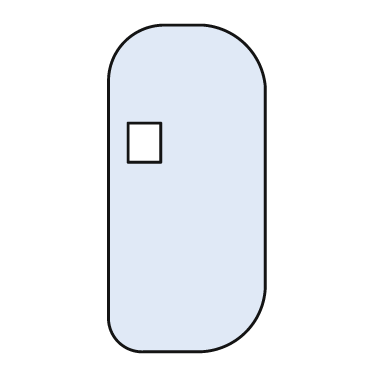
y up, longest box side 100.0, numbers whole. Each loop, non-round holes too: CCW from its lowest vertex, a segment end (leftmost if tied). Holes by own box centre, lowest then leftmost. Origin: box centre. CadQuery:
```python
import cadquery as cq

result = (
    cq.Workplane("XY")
    .moveTo(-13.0, -50.0)
    .lineTo(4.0, -50.0)
    .threePointArc((18.0, -44.0), (24.0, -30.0))
    .lineTo(24.0, 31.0)
    .threePointArc((18.0, 44.0), (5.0, 50.0))
    .lineTo(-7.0, 50.0)
    .threePointArc((-19.0, 45.0), (-24.0, 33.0))
    .lineTo(-24.0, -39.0)
    .threePointArc((-21.0, -47.0), (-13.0, -50.0))
    .close()
    .moveTo(-18.0, 8.0)
    .lineTo(-8.0, 8.0)
    .lineTo(-8.0, 20.0)
    .lineTo(-18.0, 20.0)
    .close()
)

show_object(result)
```